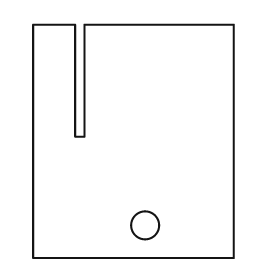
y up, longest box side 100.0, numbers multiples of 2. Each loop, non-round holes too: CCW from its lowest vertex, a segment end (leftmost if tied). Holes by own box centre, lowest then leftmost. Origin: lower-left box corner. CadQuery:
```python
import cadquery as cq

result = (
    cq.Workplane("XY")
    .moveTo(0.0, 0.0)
    .lineTo(86.0, 0.0)
    .lineTo(86.0, 100.0)
    .lineTo(22.0, 100.0)
    .lineTo(22.0, 52.0)
    .lineTo(18.0, 52.0)
    .lineTo(18.0, 100.0)
    .lineTo(0.0, 100.0)
    .close()
    .moveTo(48.0, 14.0)
    .circle(6.0)
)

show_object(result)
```